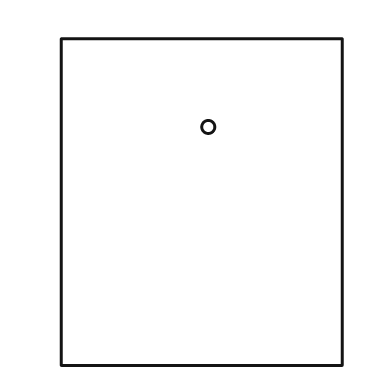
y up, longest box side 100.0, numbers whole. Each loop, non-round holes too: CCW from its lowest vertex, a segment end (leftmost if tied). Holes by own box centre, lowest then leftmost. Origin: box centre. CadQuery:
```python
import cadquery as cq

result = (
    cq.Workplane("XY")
    .moveTo(-43.0, -50.0)
    .lineTo(43.0, -50.0)
    .lineTo(43.0, 50.0)
    .lineTo(-43.0, 50.0)
    .close()
    .moveTo(2.0, 23.0)
    .circle(2.0)
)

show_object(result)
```